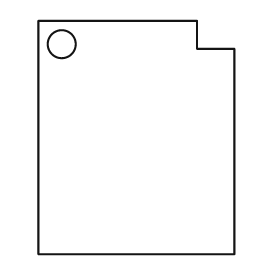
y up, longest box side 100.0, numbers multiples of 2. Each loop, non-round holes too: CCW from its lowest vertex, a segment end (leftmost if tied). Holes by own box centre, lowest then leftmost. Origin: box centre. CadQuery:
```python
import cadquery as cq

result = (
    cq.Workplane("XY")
    .moveTo(-42.0, -50.0)
    .lineTo(42.0, -50.0)
    .lineTo(42.0, 38.0)
    .lineTo(26.0, 38.0)
    .lineTo(26.0, 50.0)
    .lineTo(-42.0, 50.0)
    .close()
    .moveTo(-32.0, 40.0)
    .circle(6.0)
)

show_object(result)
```